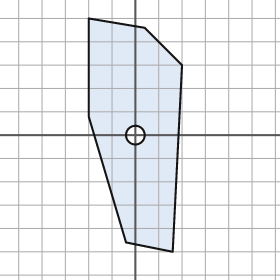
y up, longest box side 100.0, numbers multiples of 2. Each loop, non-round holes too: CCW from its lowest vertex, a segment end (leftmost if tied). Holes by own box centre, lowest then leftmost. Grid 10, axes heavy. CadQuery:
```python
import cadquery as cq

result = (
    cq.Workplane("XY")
    .moveTo(16.0, -50.0)
    .lineTo(20.0, 30.0)
    .lineTo(4.0, 46.0)
    .lineTo(-20.0, 50.0)
    .lineTo(-20.0, 8.0)
    .lineTo(-4.0, -46.0)
    .close()
    .moveTo(0.0, 0.0)
    .circle(4.0)
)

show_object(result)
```